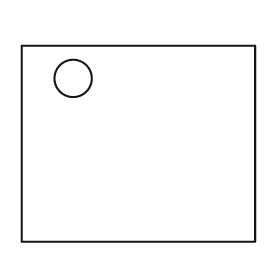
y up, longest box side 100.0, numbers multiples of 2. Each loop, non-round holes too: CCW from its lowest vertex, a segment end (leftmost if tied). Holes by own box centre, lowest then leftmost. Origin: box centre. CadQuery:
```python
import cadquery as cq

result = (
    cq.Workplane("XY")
    .moveTo(-50.0, -42.0)
    .lineTo(50.0, -42.0)
    .lineTo(50.0, 42.0)
    .lineTo(-50.0, 42.0)
    .close()
    .moveTo(-28.0, 28.0)
    .circle(8.0)
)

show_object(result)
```